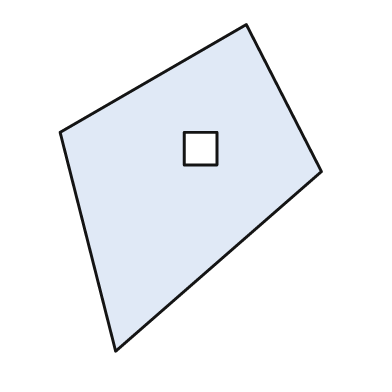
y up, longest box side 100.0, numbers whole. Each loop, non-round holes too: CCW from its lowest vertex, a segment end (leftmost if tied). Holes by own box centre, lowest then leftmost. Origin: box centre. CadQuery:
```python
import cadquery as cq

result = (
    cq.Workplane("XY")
    .moveTo(-23.0, -50.0)
    .lineTo(40.0, 5.0)
    .lineTo(17.0, 50.0)
    .lineTo(-40.0, 17.0)
    .close()
    .moveTo(-2.0, 7.0)
    .lineTo(8.0, 7.0)
    .lineTo(8.0, 17.0)
    .lineTo(-2.0, 17.0)
    .close()
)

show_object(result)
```